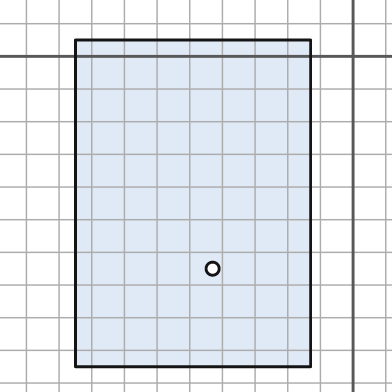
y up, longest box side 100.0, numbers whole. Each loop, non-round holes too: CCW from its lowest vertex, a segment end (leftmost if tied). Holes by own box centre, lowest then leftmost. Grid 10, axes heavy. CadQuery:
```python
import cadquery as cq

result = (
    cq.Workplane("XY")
    .moveTo(-85.0, -95.0)
    .lineTo(-13.0, -95.0)
    .lineTo(-13.0, 5.0)
    .lineTo(-85.0, 5.0)
    .close()
    .moveTo(-43.0, -65.0)
    .circle(2.0)
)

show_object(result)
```